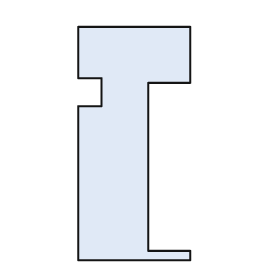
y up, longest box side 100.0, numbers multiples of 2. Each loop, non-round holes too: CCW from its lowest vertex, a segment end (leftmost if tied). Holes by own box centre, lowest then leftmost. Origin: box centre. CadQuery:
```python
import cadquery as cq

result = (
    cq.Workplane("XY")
    .moveTo(-24.0, -50.0)
    .lineTo(24.0, -50.0)
    .lineTo(24.0, -46.0)
    .lineTo(6.0, -46.0)
    .lineTo(6.0, 26.0)
    .lineTo(24.0, 26.0)
    .lineTo(24.0, 50.0)
    .lineTo(-24.0, 50.0)
    .lineTo(-24.0, 28.0)
    .lineTo(-14.0, 28.0)
    .lineTo(-14.0, 16.0)
    .lineTo(-24.0, 16.0)
    .close()
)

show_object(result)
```